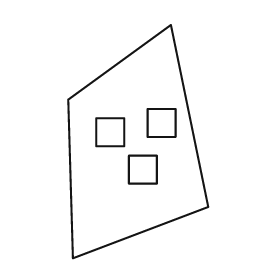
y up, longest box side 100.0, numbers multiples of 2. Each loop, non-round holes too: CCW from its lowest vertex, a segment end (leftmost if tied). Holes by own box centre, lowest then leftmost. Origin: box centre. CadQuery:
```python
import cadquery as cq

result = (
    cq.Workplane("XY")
    .moveTo(-28.0, -50.0)
    .lineTo(30.0, -28.0)
    .lineTo(14.0, 50.0)
    .lineTo(-30.0, 18.0)
    .close()
    .moveTo(-4.0, -18.0)
    .lineTo(8.0, -18.0)
    .lineTo(8.0, -6.0)
    .lineTo(-4.0, -6.0)
    .close()
    .moveTo(-18.0, -2.0)
    .lineTo(-6.0, -2.0)
    .lineTo(-6.0, 10.0)
    .lineTo(-18.0, 10.0)
    .close()
    .moveTo(4.0, 2.0)
    .lineTo(16.0, 2.0)
    .lineTo(16.0, 14.0)
    .lineTo(4.0, 14.0)
    .close()
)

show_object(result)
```